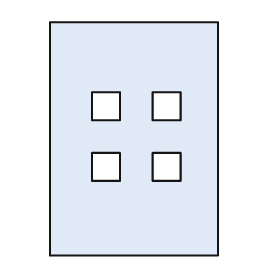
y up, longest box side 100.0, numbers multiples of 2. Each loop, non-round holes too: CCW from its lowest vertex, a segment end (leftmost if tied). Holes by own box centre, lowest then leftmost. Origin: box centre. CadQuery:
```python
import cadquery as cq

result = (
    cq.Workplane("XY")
    .moveTo(-36.0, -50.0)
    .lineTo(36.0, -50.0)
    .lineTo(36.0, 50.0)
    .lineTo(-36.0, 50.0)
    .close()
    .moveTo(-18.0, -18.0)
    .lineTo(-6.0, -18.0)
    .lineTo(-6.0, -6.0)
    .lineTo(-18.0, -6.0)
    .close()
    .moveTo(8.0, -18.0)
    .lineTo(20.0, -18.0)
    .lineTo(20.0, -6.0)
    .lineTo(8.0, -6.0)
    .close()
    .moveTo(-18.0, 8.0)
    .lineTo(-6.0, 8.0)
    .lineTo(-6.0, 20.0)
    .lineTo(-18.0, 20.0)
    .close()
    .moveTo(8.0, 8.0)
    .lineTo(20.0, 8.0)
    .lineTo(20.0, 20.0)
    .lineTo(8.0, 20.0)
    .close()
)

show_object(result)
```